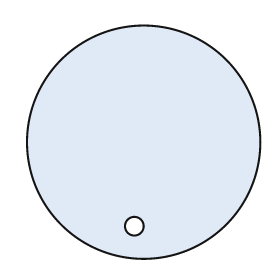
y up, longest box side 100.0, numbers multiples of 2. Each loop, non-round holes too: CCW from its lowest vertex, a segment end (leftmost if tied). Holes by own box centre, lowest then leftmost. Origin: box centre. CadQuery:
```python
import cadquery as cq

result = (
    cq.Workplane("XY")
    .moveTo(0.0, 0.0)
    .circle(50.0)
    .moveTo(-4.0, -36.0)
    .circle(4.0)
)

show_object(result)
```